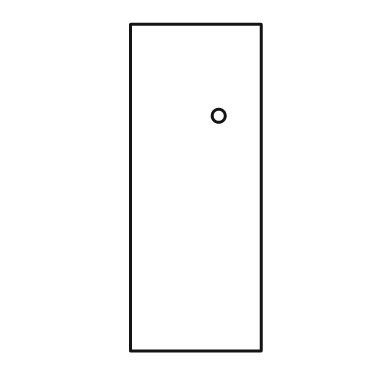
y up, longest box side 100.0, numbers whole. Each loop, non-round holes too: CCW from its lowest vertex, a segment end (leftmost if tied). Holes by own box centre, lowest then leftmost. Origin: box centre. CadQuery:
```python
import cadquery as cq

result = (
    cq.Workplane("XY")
    .moveTo(-20.0, -50.0)
    .lineTo(20.0, -50.0)
    .lineTo(20.0, 50.0)
    .lineTo(-20.0, 50.0)
    .close()
    .moveTo(7.0, 22.0)
    .circle(2.0)
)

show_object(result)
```